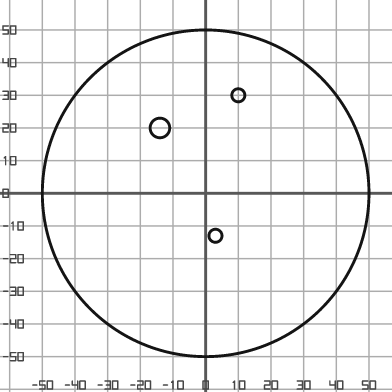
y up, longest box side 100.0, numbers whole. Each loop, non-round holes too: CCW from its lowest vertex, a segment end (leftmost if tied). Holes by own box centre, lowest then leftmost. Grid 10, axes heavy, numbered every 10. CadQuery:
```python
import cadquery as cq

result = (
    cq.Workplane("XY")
    .moveTo(0.0, 0.0)
    .circle(50.0)
    .moveTo(3.0, -13.0)
    .circle(2.0)
    .moveTo(-14.0, 20.0)
    .circle(3.0)
    .moveTo(10.0, 30.0)
    .circle(2.0)
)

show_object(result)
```